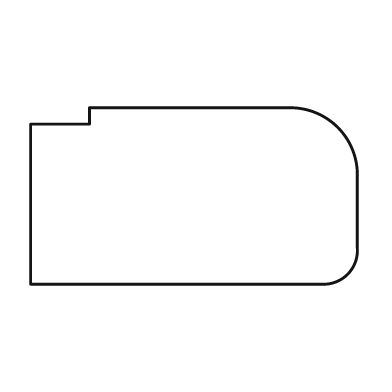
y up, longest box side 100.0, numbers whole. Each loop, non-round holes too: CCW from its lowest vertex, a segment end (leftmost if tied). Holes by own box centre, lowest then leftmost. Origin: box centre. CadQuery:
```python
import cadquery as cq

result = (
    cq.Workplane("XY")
    .moveTo(-50.0, -27.0)
    .lineTo(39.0, -27.0)
    .threePointArc((47.0, -24.0), (50.0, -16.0))
    .lineTo(50.0, 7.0)
    .threePointArc((44.0, 21.0), (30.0, 27.0))
    .lineTo(-32.0, 27.0)
    .lineTo(-32.0, 22.0)
    .lineTo(-50.0, 22.0)
    .close()
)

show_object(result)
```